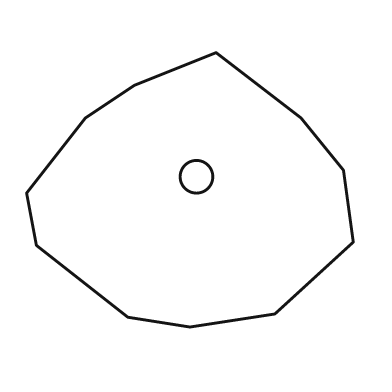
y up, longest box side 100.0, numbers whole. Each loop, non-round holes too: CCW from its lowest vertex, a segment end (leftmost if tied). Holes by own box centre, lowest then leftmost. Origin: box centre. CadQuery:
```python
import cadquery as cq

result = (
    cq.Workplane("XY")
    .moveTo(0.0, -42.0)
    .lineTo(26.0, -38.0)
    .lineTo(50.0, -16.0)
    .lineTo(47.0, 6.0)
    .lineTo(34.0, 22.0)
    .lineTo(8.0, 42.0)
    .lineTo(-17.0, 32.0)
    .lineTo(-32.0, 22.0)
    .lineTo(-50.0, -1.0)
    .lineTo(-47.0, -17.0)
    .lineTo(-19.0, -39.0)
    .close()
    .moveTo(2.0, 4.0)
    .circle(5.0)
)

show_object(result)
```